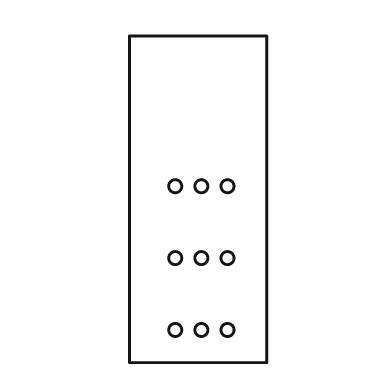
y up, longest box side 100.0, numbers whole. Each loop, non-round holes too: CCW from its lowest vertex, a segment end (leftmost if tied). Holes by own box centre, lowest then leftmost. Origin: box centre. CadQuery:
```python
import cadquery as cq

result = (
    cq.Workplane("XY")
    .moveTo(-21.0, -50.0)
    .lineTo(21.0, -50.0)
    .lineTo(21.0, 50.0)
    .lineTo(-21.0, 50.0)
    .close()
    .moveTo(-7.0, -40.0)
    .circle(2.0)
    .moveTo(1.0, -40.0)
    .circle(2.0)
    .moveTo(9.0, -40.0)
    .circle(2.0)
    .moveTo(-7.0, -18.0)
    .circle(2.0)
    .moveTo(1.0, -18.0)
    .circle(2.0)
    .moveTo(9.0, -18.0)
    .circle(2.0)
    .moveTo(-7.0, 4.0)
    .circle(2.0)
    .moveTo(1.0, 4.0)
    .circle(2.0)
    .moveTo(9.0, 4.0)
    .circle(2.0)
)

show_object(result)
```